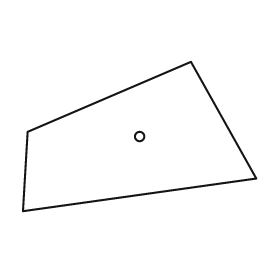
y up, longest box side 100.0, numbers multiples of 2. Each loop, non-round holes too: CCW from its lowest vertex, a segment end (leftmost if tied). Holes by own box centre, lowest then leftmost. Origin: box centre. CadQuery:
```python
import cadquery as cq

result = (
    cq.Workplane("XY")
    .moveTo(-50.0, -32.0)
    .lineTo(50.0, -18.0)
    .lineTo(22.0, 32.0)
    .lineTo(-48.0, 2.0)
    .close()
    .moveTo(0.0, 0.0)
    .circle(2.0)
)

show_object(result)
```